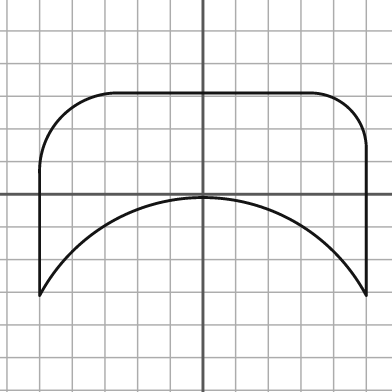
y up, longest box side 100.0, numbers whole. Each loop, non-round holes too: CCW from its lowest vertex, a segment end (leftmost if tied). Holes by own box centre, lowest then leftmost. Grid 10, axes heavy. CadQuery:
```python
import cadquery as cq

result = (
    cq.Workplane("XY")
    .moveTo(-50.0, -31.0)
    .threePointArc((0.0, -1.0), (50.0, -31.0))
    .lineTo(50.0, 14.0)
    .threePointArc((45.0, 26.0), (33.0, 31.0))
    .lineTo(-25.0, 31.0)
    .threePointArc((-43.0, 24.0), (-50.0, 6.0))
    .close()
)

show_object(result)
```